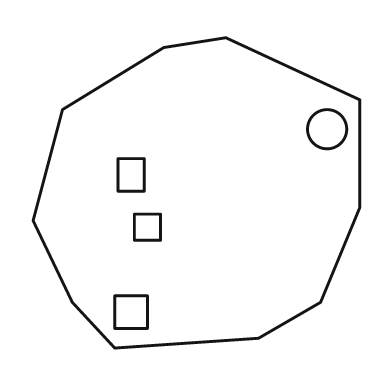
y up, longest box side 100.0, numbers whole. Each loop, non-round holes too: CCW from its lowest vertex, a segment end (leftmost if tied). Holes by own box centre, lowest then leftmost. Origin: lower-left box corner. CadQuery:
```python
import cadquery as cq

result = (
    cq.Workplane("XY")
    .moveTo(25.0, 0.0)
    .lineTo(69.0, 3.0)
    .lineTo(88.0, 14.0)
    .lineTo(100.0, 43.0)
    .lineTo(100.0, 76.0)
    .lineTo(59.0, 95.0)
    .lineTo(40.0, 92.0)
    .lineTo(9.0, 73.0)
    .lineTo(0.0, 39.0)
    .lineTo(12.0, 14.0)
    .close()
    .moveTo(25.0, 6.0)
    .lineTo(35.0, 6.0)
    .lineTo(35.0, 16.0)
    .lineTo(25.0, 16.0)
    .close()
    .moveTo(31.0, 33.0)
    .lineTo(39.0, 33.0)
    .lineTo(39.0, 41.0)
    .lineTo(31.0, 41.0)
    .close()
    .moveTo(26.0, 48.0)
    .lineTo(34.0, 48.0)
    .lineTo(34.0, 58.0)
    .lineTo(26.0, 58.0)
    .close()
    .moveTo(90.0, 67.0)
    .circle(6.0)
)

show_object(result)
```